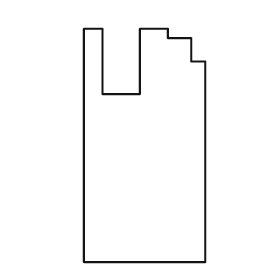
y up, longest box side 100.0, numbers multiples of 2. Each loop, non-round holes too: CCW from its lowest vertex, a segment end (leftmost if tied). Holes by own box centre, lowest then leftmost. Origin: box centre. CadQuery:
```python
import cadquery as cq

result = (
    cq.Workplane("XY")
    .moveTo(-26.0, -50.0)
    .lineTo(26.0, -50.0)
    .lineTo(26.0, 36.0)
    .lineTo(20.0, 36.0)
    .lineTo(20.0, 46.0)
    .lineTo(10.0, 46.0)
    .lineTo(10.0, 50.0)
    .lineTo(-2.0, 50.0)
    .lineTo(-2.0, 22.0)
    .lineTo(-18.0, 22.0)
    .lineTo(-18.0, 50.0)
    .lineTo(-26.0, 50.0)
    .close()
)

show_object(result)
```